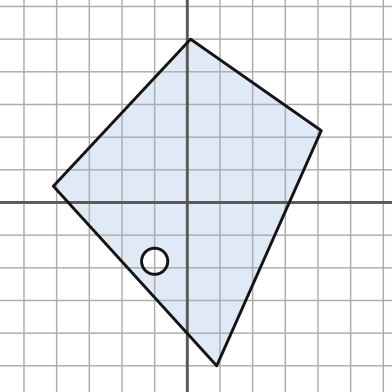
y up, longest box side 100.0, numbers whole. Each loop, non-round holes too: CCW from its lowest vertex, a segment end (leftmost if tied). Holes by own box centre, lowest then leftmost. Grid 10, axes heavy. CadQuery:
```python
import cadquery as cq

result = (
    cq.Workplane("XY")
    .moveTo(9.0, -50.0)
    .lineTo(41.0, 22.0)
    .lineTo(1.0, 50.0)
    .lineTo(-41.0, 5.0)
    .close()
    .moveTo(-10.0, -18.0)
    .circle(4.0)
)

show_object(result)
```